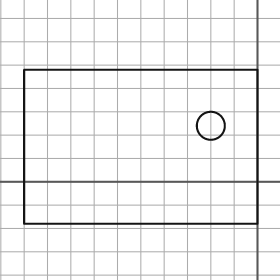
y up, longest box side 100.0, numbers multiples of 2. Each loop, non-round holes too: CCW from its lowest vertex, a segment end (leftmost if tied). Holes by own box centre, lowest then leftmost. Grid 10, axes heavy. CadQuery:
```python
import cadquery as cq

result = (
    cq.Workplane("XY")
    .moveTo(-100.0, -18.0)
    .lineTo(0.0, -18.0)
    .lineTo(0.0, 48.0)
    .lineTo(-100.0, 48.0)
    .close()
    .moveTo(-20.0, 24.0)
    .circle(6.0)
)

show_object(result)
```